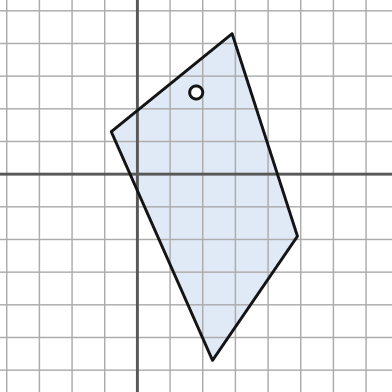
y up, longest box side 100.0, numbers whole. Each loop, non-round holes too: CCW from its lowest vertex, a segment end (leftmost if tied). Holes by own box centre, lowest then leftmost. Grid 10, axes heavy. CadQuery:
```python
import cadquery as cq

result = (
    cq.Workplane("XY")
    .moveTo(23.0, -57.0)
    .lineTo(49.0, -19.0)
    .lineTo(29.0, 43.0)
    .lineTo(-8.0, 13.0)
    .close()
    .moveTo(18.0, 25.0)
    .circle(2.0)
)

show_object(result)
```